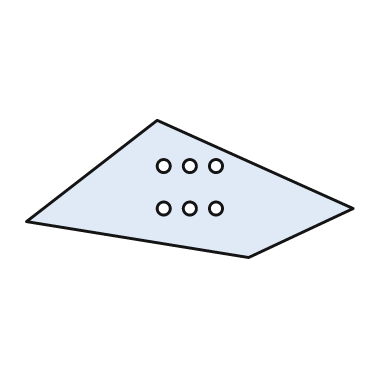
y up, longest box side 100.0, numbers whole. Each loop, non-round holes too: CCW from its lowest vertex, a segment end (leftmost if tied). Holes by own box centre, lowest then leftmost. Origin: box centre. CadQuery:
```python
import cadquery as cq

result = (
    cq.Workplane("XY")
    .moveTo(18.0, -21.0)
    .lineTo(50.0, -6.0)
    .lineTo(-10.0, 21.0)
    .lineTo(-50.0, -10.0)
    .close()
    .moveTo(-8.0, -6.0)
    .circle(2.0)
    .moveTo(0.0, -6.0)
    .circle(2.0)
    .moveTo(8.0, -6.0)
    .circle(2.0)
    .moveTo(-8.0, 7.0)
    .circle(2.0)
    .moveTo(0.0, 7.0)
    .circle(2.0)
    .moveTo(8.0, 7.0)
    .circle(2.0)
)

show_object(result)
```